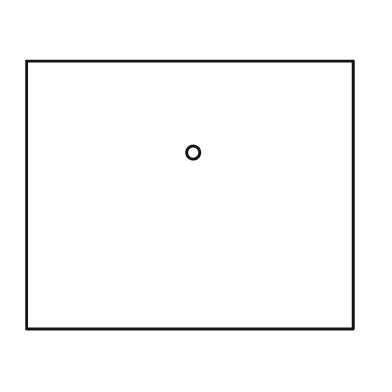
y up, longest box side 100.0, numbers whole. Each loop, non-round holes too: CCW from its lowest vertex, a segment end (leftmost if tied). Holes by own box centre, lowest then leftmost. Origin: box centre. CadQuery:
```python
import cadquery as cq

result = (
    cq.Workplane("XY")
    .moveTo(-50.0, -41.0)
    .lineTo(50.0, -41.0)
    .lineTo(50.0, 41.0)
    .lineTo(-50.0, 41.0)
    .close()
    .moveTo(1.0, 13.0)
    .circle(2.0)
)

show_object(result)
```